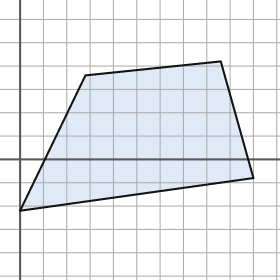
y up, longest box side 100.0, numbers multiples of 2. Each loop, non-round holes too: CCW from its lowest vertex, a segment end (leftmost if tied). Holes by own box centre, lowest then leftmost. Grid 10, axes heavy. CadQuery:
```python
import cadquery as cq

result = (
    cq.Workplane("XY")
    .moveTo(0.0, -22.0)
    .lineTo(100.0, -8.0)
    .lineTo(86.0, 42.0)
    .lineTo(28.0, 36.0)
    .close()
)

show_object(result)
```